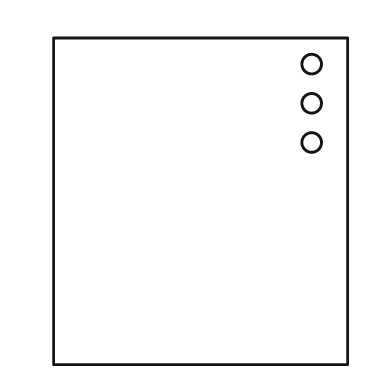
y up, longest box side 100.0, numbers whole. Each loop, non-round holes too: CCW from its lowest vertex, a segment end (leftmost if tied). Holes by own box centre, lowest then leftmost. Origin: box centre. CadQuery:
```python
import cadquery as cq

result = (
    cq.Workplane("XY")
    .moveTo(-45.0, -50.0)
    .lineTo(45.0, -50.0)
    .lineTo(45.0, 50.0)
    .lineTo(-45.0, 50.0)
    .close()
    .moveTo(34.0, 18.0)
    .circle(3.0)
    .moveTo(34.0, 30.0)
    .circle(3.0)
    .moveTo(34.0, 42.0)
    .circle(3.0)
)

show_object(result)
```